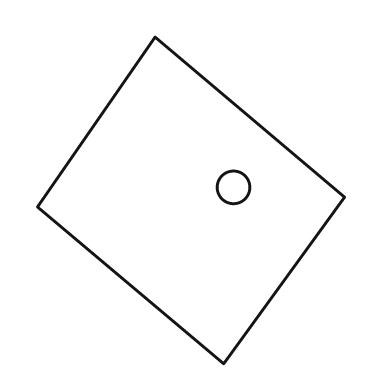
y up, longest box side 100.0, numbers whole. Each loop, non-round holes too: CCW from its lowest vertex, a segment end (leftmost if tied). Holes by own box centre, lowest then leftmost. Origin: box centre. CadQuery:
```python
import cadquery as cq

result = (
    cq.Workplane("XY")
    .moveTo(10.0, -50.0)
    .lineTo(47.0, 1.0)
    .lineTo(-11.0, 50.0)
    .lineTo(-47.0, -2.0)
    .close()
    .moveTo(13.0, 4.0)
    .circle(5.0)
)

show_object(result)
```